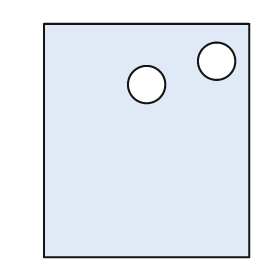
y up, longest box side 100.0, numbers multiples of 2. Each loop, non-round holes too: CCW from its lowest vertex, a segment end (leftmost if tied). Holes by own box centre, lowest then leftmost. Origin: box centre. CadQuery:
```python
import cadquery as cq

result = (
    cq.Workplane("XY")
    .moveTo(-44.0, -50.0)
    .lineTo(44.0, -50.0)
    .lineTo(44.0, 50.0)
    .lineTo(-44.0, 50.0)
    .close()
    .moveTo(0.0, 24.0)
    .circle(8.0)
    .moveTo(30.0, 34.0)
    .circle(8.0)
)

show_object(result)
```